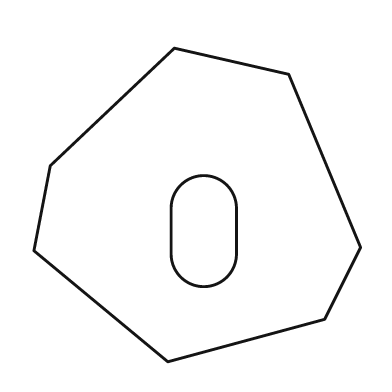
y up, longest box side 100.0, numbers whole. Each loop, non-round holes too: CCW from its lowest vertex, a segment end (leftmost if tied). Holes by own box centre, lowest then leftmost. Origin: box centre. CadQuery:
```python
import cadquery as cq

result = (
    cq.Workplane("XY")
    .moveTo(-9.0, -48.0)
    .lineTo(39.0, -35.0)
    .lineTo(50.0, -13.0)
    .lineTo(28.0, 40.0)
    .lineTo(-7.0, 48.0)
    .lineTo(-45.0, 12.0)
    .lineTo(-50.0, -14.0)
    .close()
    .moveTo(-8.0, -15.0)
    .threePointArc((2.0, -25.0), (12.0, -15.0))
    .lineTo(12.0, -1.0)
    .threePointArc((2.0, 9.0), (-8.0, -1.0))
    .close()
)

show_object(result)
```